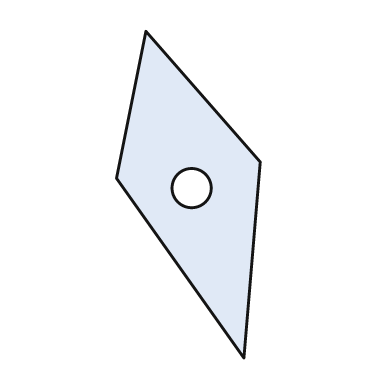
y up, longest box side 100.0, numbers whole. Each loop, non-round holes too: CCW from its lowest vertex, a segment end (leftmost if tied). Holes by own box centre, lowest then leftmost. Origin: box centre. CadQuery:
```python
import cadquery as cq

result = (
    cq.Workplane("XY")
    .moveTo(17.0, -50.0)
    .lineTo(22.0, 10.0)
    .lineTo(-13.0, 50.0)
    .lineTo(-22.0, 5.0)
    .close()
    .moveTo(1.0, 2.0)
    .circle(6.0)
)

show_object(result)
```